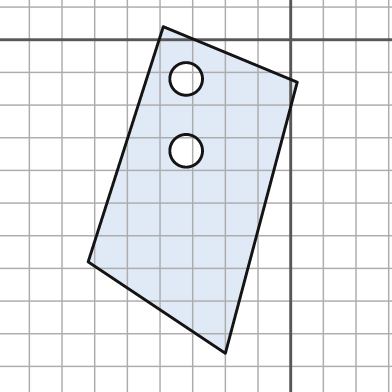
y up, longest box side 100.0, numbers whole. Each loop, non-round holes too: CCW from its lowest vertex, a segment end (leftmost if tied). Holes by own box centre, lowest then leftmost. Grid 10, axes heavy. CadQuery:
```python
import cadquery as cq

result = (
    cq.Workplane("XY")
    .moveTo(-20.0, -96.0)
    .lineTo(2.0, -13.0)
    .lineTo(-39.0, 4.0)
    .lineTo(-62.0, -68.0)
    .close()
    .moveTo(-32.0, -34.0)
    .circle(5.0)
    .moveTo(-32.0, -12.0)
    .circle(5.0)
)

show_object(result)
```